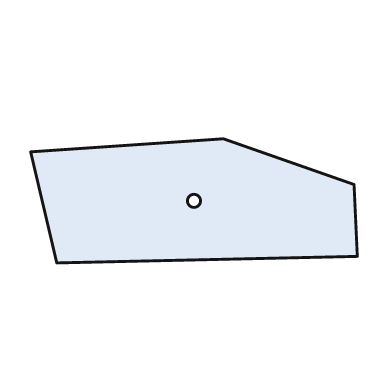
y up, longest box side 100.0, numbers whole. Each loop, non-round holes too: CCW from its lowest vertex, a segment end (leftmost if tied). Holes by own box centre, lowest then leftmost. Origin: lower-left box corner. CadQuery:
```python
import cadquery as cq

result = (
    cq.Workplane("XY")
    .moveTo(8.0, 0.0)
    .lineTo(100.0, 2.0)
    .lineTo(99.0, 24.0)
    .lineTo(59.0, 38.0)
    .lineTo(0.0, 34.0)
    .close()
    .moveTo(50.0, 19.0)
    .circle(2.0)
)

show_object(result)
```